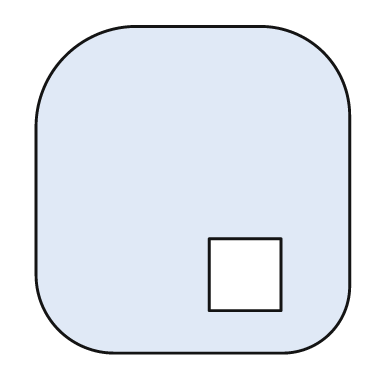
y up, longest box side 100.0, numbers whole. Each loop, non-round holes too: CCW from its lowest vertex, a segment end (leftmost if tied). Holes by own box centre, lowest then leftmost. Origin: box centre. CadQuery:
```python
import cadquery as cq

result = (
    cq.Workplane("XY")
    .moveTo(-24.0, -50.0)
    .lineTo(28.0, -50.0)
    .threePointArc((42.0, -44.0), (48.0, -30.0))
    .lineTo(48.0, 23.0)
    .threePointArc((40.0, 42.0), (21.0, 50.0))
    .lineTo(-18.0, 50.0)
    .threePointArc((-39.0, 41.0), (-48.0, 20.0))
    .lineTo(-48.0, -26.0)
    .threePointArc((-41.0, -43.0), (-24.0, -50.0))
    .close()
    .moveTo(5.0, -37.0)
    .lineTo(27.0, -37.0)
    .lineTo(27.0, -15.0)
    .lineTo(5.0, -15.0)
    .close()
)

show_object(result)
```